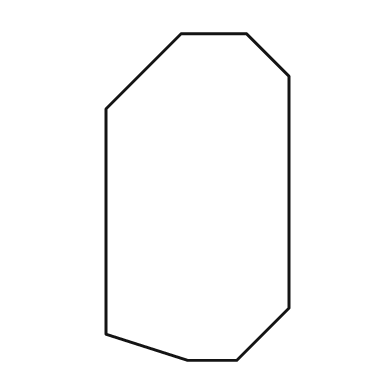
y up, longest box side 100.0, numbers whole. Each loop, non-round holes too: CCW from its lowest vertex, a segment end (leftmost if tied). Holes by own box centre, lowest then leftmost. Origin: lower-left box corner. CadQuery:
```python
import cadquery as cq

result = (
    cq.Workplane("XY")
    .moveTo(25.0, 0.0)
    .lineTo(40.0, 0.0)
    .lineTo(56.0, 16.0)
    .lineTo(56.0, 87.0)
    .lineTo(43.0, 100.0)
    .lineTo(23.0, 100.0)
    .lineTo(0.0, 77.0)
    .lineTo(0.0, 8.0)
    .close()
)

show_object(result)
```